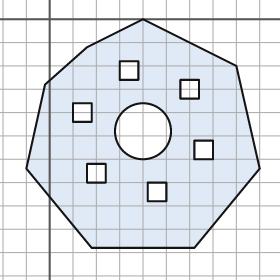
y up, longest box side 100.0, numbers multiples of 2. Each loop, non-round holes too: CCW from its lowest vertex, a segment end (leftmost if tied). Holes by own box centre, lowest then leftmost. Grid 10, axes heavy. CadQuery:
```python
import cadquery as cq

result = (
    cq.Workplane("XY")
    .moveTo(18.0, -98.0)
    .lineTo(62.0, -98.0)
    .lineTo(90.0, -64.0)
    .lineTo(80.0, -20.0)
    .lineTo(40.0, 0.0)
    .lineTo(16.0, -12.0)
    .lineTo(-2.0, -28.0)
    .lineTo(-10.0, -64.0)
    .close()
    .moveTo(42.0, -78.0)
    .lineTo(50.0, -78.0)
    .lineTo(50.0, -70.0)
    .lineTo(42.0, -70.0)
    .close()
    .moveTo(16.0, -70.0)
    .lineTo(24.0, -70.0)
    .lineTo(24.0, -62.0)
    .lineTo(16.0, -62.0)
    .close()
    .moveTo(62.0, -60.0)
    .lineTo(70.0, -60.0)
    .lineTo(70.0, -52.0)
    .lineTo(62.0, -52.0)
    .close()
    .moveTo(40.0, -48.0)
    .circle(12.0)
    .moveTo(10.0, -44.0)
    .lineTo(18.0, -44.0)
    .lineTo(18.0, -36.0)
    .lineTo(10.0, -36.0)
    .close()
    .moveTo(56.0, -34.0)
    .lineTo(64.0, -34.0)
    .lineTo(64.0, -26.0)
    .lineTo(56.0, -26.0)
    .close()
    .moveTo(30.0, -26.0)
    .lineTo(38.0, -26.0)
    .lineTo(38.0, -18.0)
    .lineTo(30.0, -18.0)
    .close()
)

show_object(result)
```